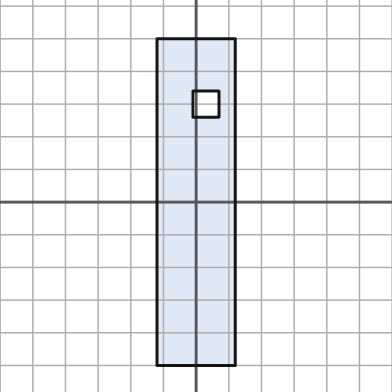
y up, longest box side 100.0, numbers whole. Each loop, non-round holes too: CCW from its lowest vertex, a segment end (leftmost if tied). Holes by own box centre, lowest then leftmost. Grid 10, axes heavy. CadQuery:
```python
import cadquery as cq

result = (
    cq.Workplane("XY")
    .moveTo(-12.0, -50.0)
    .lineTo(12.0, -50.0)
    .lineTo(12.0, 50.0)
    .lineTo(-12.0, 50.0)
    .close()
    .moveTo(-1.0, 26.0)
    .lineTo(7.0, 26.0)
    .lineTo(7.0, 34.0)
    .lineTo(-1.0, 34.0)
    .close()
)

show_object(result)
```